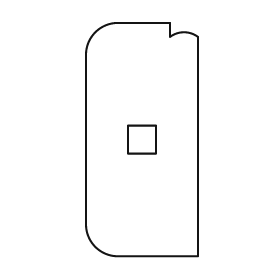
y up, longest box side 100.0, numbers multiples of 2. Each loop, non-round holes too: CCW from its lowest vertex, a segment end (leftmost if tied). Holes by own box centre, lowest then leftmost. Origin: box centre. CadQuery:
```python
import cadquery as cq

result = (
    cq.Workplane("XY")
    .moveTo(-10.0, -50.0)
    .lineTo(24.0, -50.0)
    .lineTo(24.0, 44.0)
    .threePointArc((18.0, 46.0), (12.0, 44.0))
    .lineTo(12.0, 50.0)
    .lineTo(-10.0, 50.0)
    .threePointArc((-20.0, 46.0), (-24.0, 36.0))
    .lineTo(-24.0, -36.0)
    .threePointArc((-20.0, -46.0), (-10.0, -50.0))
    .close()
    .moveTo(-6.0, -6.0)
    .lineTo(6.0, -6.0)
    .lineTo(6.0, 6.0)
    .lineTo(-6.0, 6.0)
    .close()
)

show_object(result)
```